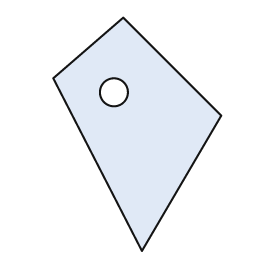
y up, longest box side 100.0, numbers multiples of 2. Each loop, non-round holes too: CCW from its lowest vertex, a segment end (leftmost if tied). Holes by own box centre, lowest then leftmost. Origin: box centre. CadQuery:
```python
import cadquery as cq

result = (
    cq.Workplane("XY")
    .moveTo(2.0, -50.0)
    .lineTo(36.0, 8.0)
    .lineTo(-6.0, 50.0)
    .lineTo(-36.0, 24.0)
    .close()
    .moveTo(-10.0, 18.0)
    .circle(6.0)
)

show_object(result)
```